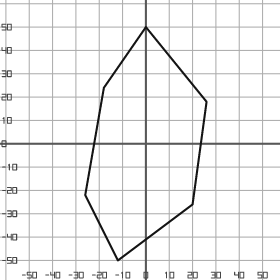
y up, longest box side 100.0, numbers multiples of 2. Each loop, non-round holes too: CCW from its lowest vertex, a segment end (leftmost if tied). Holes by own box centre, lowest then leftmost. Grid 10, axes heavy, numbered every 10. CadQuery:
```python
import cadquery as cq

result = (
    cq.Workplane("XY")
    .moveTo(-12.0, -50.0)
    .lineTo(20.0, -26.0)
    .lineTo(26.0, 18.0)
    .lineTo(0.0, 50.0)
    .lineTo(-18.0, 24.0)
    .lineTo(-26.0, -22.0)
    .close()
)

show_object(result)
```